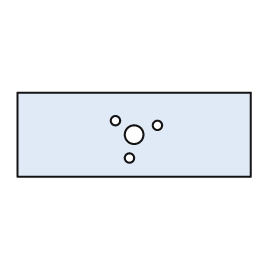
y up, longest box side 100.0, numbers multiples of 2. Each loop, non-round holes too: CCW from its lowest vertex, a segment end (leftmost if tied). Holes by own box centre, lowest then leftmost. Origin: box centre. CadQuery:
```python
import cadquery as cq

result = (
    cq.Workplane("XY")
    .moveTo(-50.0, -18.0)
    .lineTo(50.0, -18.0)
    .lineTo(50.0, 18.0)
    .lineTo(-50.0, 18.0)
    .close()
    .moveTo(-2.0, -10.0)
    .circle(2.0)
    .moveTo(0.0, 0.0)
    .circle(4.0)
    .moveTo(10.0, 4.0)
    .circle(2.0)
    .moveTo(-8.0, 6.0)
    .circle(2.0)
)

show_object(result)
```